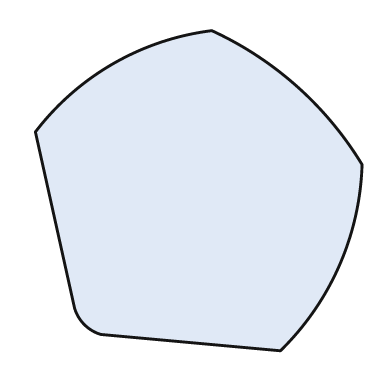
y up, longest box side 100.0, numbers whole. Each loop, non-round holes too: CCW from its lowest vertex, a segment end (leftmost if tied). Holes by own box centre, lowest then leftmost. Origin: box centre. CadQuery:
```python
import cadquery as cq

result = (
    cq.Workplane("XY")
    .moveTo(25.0, -49.0)
    .threePointArc((43.0, -23.0), (50.0, 8.0))
    .threePointArc((30.0, 32.0), (4.0, 49.0))
    .threePointArc((-26.0, 39.0), (-50.0, 18.0))
    .lineTo(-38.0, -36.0)
    .threePointArc((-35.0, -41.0), (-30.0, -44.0))
    .close()
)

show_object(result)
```